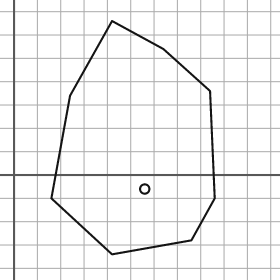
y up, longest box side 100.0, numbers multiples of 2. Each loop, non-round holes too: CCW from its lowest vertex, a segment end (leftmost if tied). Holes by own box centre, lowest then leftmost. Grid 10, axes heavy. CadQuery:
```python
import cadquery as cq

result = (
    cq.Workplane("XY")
    .moveTo(42.0, -34.0)
    .lineTo(76.0, -28.0)
    .lineTo(86.0, -10.0)
    .lineTo(84.0, 36.0)
    .lineTo(64.0, 54.0)
    .lineTo(42.0, 66.0)
    .lineTo(24.0, 34.0)
    .lineTo(16.0, -10.0)
    .close()
    .moveTo(56.0, -6.0)
    .circle(2.0)
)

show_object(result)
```